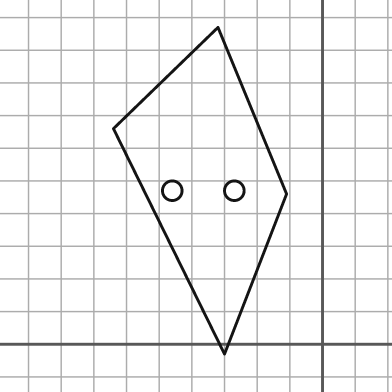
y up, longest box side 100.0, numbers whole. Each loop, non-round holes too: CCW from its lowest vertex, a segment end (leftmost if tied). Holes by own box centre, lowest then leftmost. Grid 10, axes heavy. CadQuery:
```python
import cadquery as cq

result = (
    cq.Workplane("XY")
    .moveTo(-30.0, -3.0)
    .lineTo(-11.0, 46.0)
    .lineTo(-32.0, 97.0)
    .lineTo(-64.0, 66.0)
    .close()
    .moveTo(-46.0, 47.0)
    .circle(3.0)
    .moveTo(-27.0, 47.0)
    .circle(3.0)
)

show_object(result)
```